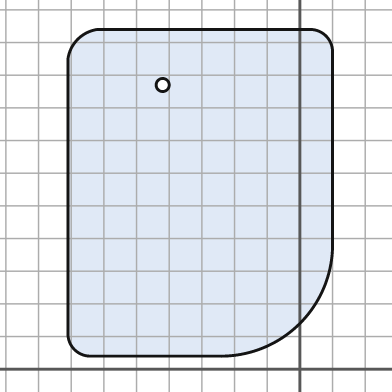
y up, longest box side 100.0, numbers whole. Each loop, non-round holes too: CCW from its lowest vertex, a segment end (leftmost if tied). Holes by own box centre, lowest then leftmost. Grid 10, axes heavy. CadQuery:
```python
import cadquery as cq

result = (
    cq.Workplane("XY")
    .moveTo(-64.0, 4.0)
    .lineTo(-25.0, 4.0)
    .threePointArc((0.0, 14.0), (10.0, 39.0))
    .lineTo(10.0, 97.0)
    .threePointArc((8.0, 102.0), (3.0, 104.0))
    .lineTo(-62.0, 104.0)
    .threePointArc((-68.0, 101.0), (-71.0, 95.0))
    .lineTo(-71.0, 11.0)
    .threePointArc((-69.0, 6.0), (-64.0, 4.0))
    .close()
    .moveTo(-42.0, 87.0)
    .circle(2.0)
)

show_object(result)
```